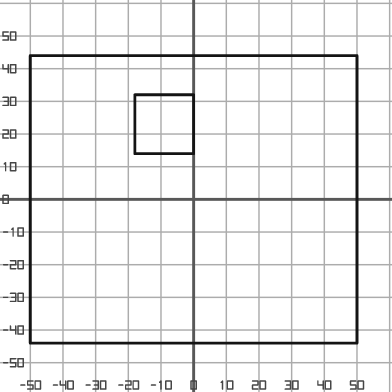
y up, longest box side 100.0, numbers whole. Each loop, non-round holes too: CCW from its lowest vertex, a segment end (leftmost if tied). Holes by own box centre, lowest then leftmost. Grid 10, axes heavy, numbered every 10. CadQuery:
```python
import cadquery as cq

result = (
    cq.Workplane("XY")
    .moveTo(-50.0, -44.0)
    .lineTo(50.0, -44.0)
    .lineTo(50.0, 44.0)
    .lineTo(-50.0, 44.0)
    .close()
    .moveTo(-18.0, 14.0)
    .lineTo(0.0, 14.0)
    .lineTo(0.0, 32.0)
    .lineTo(-18.0, 32.0)
    .close()
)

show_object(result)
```